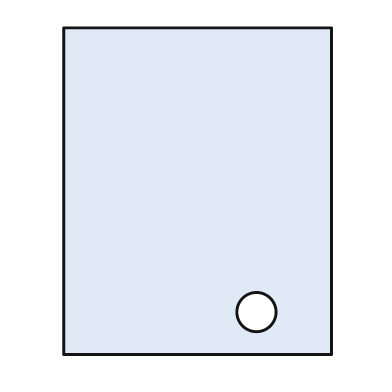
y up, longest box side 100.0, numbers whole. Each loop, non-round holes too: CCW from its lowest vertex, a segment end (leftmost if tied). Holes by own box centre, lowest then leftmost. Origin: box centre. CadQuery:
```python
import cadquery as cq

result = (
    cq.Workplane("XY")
    .moveTo(-41.0, -50.0)
    .lineTo(41.0, -50.0)
    .lineTo(41.0, 50.0)
    .lineTo(-41.0, 50.0)
    .close()
    .moveTo(18.0, -37.0)
    .circle(6.0)
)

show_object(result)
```